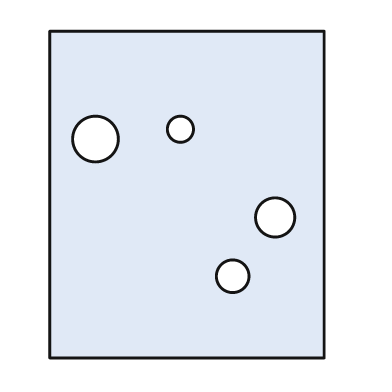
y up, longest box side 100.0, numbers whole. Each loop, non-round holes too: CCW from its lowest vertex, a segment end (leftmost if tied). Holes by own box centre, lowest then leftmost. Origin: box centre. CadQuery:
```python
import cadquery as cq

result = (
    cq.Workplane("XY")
    .moveTo(-42.0, -50.0)
    .lineTo(42.0, -50.0)
    .lineTo(42.0, 50.0)
    .lineTo(-42.0, 50.0)
    .close()
    .moveTo(14.0, -25.0)
    .circle(5.0)
    .moveTo(27.0, -7.0)
    .circle(6.0)
    .moveTo(-28.0, 17.0)
    .circle(7.0)
    .moveTo(-2.0, 20.0)
    .circle(4.0)
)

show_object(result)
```